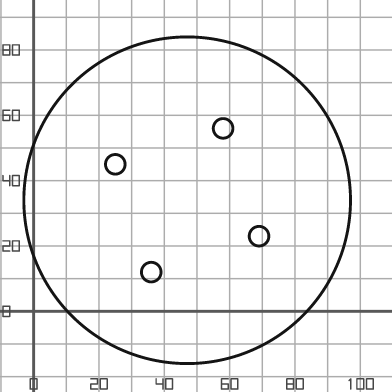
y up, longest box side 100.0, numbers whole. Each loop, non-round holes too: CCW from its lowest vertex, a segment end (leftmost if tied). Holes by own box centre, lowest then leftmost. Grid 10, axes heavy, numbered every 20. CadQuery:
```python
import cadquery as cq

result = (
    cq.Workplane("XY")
    .moveTo(47.0, 34.0)
    .circle(50.0)
    .moveTo(36.0, 12.0)
    .circle(3.0)
    .moveTo(69.0, 23.0)
    .circle(3.0)
    .moveTo(25.0, 45.0)
    .circle(3.0)
    .moveTo(58.0, 56.0)
    .circle(3.0)
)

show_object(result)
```